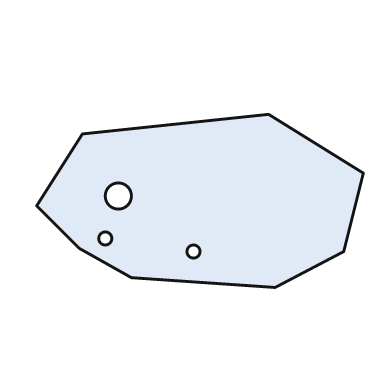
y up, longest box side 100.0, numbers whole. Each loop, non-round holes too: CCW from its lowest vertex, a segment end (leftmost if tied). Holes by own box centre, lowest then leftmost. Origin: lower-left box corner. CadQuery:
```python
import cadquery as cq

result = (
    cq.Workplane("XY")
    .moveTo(73.0, 0.0)
    .lineTo(94.0, 11.0)
    .lineTo(100.0, 35.0)
    .lineTo(71.0, 53.0)
    .lineTo(14.0, 47.0)
    .lineTo(0.0, 25.0)
    .lineTo(13.0, 12.0)
    .lineTo(29.0, 3.0)
    .close()
    .moveTo(48.0, 11.0)
    .circle(2.0)
    .moveTo(21.0, 15.0)
    .circle(2.0)
    .moveTo(25.0, 28.0)
    .circle(4.0)
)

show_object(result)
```